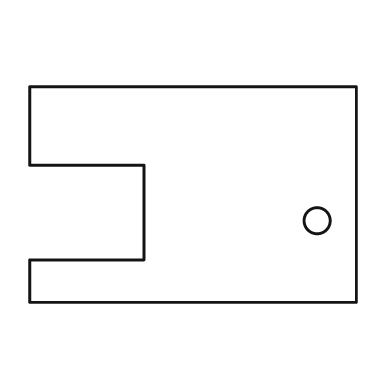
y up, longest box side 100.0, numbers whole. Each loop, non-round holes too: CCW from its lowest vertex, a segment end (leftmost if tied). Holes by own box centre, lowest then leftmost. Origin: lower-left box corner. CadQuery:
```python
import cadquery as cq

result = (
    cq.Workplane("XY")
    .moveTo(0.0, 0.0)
    .lineTo(100.0, 0.0)
    .lineTo(100.0, 66.0)
    .lineTo(0.0, 66.0)
    .lineTo(0.0, 42.0)
    .lineTo(35.0, 42.0)
    .lineTo(35.0, 13.0)
    .lineTo(0.0, 13.0)
    .close()
    .moveTo(88.0, 25.0)
    .circle(4.0)
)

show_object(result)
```